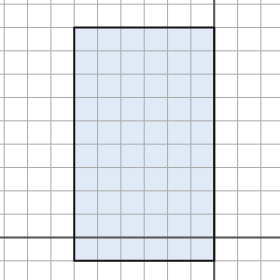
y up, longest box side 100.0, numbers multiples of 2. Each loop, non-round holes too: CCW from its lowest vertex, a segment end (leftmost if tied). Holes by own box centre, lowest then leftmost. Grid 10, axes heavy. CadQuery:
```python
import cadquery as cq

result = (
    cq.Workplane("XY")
    .moveTo(-60.0, -10.0)
    .lineTo(0.0, -10.0)
    .lineTo(0.0, 90.0)
    .lineTo(-60.0, 90.0)
    .close()
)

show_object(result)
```